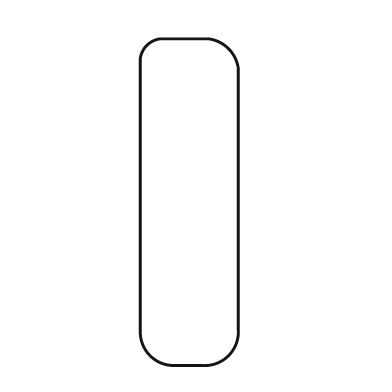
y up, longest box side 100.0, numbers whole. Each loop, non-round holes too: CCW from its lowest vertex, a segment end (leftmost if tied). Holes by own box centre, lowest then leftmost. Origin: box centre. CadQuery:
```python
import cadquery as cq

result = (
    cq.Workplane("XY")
    .moveTo(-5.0, -50.0)
    .lineTo(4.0, -50.0)
    .threePointArc((12.0, -47.0), (15.0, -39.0))
    .lineTo(15.0, 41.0)
    .threePointArc((12.0, 47.0), (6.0, 50.0))
    .lineTo(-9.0, 50.0)
    .threePointArc((-13.0, 48.0), (-15.0, 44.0))
    .lineTo(-15.0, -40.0)
    .threePointArc((-12.0, -47.0), (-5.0, -50.0))
    .close()
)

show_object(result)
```